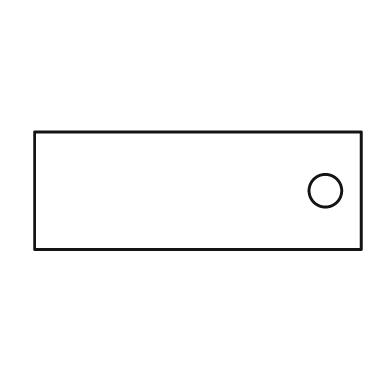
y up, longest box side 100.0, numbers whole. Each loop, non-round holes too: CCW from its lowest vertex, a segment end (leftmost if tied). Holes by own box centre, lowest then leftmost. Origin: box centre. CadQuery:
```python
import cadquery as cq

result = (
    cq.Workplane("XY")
    .moveTo(-50.0, -18.0)
    .lineTo(50.0, -18.0)
    .lineTo(50.0, 18.0)
    .lineTo(-50.0, 18.0)
    .close()
    .moveTo(39.0, 0.0)
    .circle(5.0)
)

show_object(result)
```